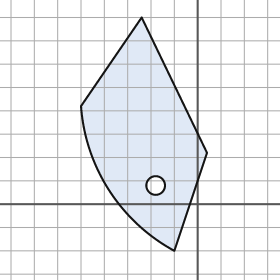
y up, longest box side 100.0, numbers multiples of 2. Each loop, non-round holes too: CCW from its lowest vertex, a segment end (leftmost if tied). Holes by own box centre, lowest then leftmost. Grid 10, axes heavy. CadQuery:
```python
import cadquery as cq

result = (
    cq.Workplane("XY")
    .moveTo(-10.0, -20.0)
    .lineTo(4.0, 22.0)
    .lineTo(-24.0, 80.0)
    .lineTo(-50.0, 42.0)
    .threePointArc((-38.0, 6.0), (-10.0, -20.0))
    .close()
    .moveTo(-18.0, 8.0)
    .circle(4.0)
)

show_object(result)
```